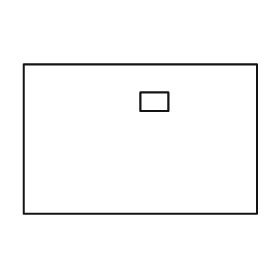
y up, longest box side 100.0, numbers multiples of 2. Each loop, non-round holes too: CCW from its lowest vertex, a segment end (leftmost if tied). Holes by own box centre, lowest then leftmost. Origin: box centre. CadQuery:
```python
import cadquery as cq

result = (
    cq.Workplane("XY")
    .moveTo(-50.0, -32.0)
    .lineTo(50.0, -32.0)
    .lineTo(50.0, 32.0)
    .lineTo(-50.0, 32.0)
    .close()
    .moveTo(0.0, 12.0)
    .lineTo(12.0, 12.0)
    .lineTo(12.0, 20.0)
    .lineTo(0.0, 20.0)
    .close()
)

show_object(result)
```